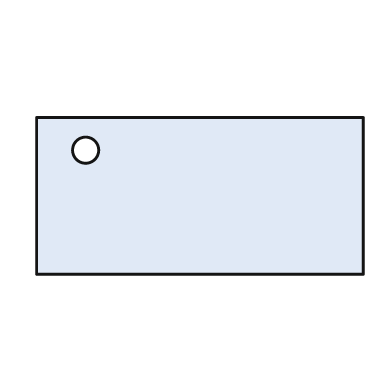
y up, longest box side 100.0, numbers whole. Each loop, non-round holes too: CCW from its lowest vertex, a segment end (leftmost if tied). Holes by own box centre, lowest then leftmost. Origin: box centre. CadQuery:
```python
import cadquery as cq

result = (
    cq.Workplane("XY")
    .moveTo(-50.0, -24.0)
    .lineTo(50.0, -24.0)
    .lineTo(50.0, 24.0)
    .lineTo(-50.0, 24.0)
    .close()
    .moveTo(-35.0, 14.0)
    .circle(4.0)
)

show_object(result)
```